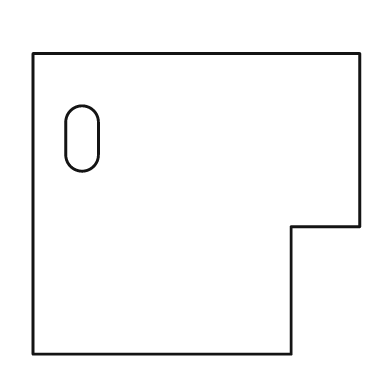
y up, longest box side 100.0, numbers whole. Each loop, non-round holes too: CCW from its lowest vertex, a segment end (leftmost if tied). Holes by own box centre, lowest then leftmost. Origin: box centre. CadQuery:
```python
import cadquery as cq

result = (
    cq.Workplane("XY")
    .moveTo(-50.0, -46.0)
    .lineTo(29.0, -46.0)
    .lineTo(29.0, -7.0)
    .lineTo(50.0, -7.0)
    .lineTo(50.0, 46.0)
    .lineTo(-50.0, 46.0)
    .close()
    .moveTo(-40.0, 15.0)
    .threePointArc((-35.0, 10.0), (-30.0, 15.0))
    .lineTo(-30.0, 25.0)
    .threePointArc((-35.0, 30.0), (-40.0, 25.0))
    .close()
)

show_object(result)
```